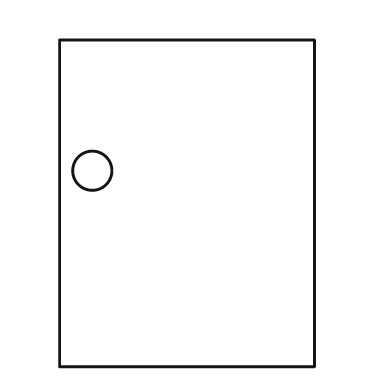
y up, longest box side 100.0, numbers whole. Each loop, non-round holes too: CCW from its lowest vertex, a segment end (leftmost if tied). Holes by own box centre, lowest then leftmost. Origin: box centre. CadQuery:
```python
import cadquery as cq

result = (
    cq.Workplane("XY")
    .moveTo(-39.0, -50.0)
    .lineTo(39.0, -50.0)
    .lineTo(39.0, 50.0)
    .lineTo(-39.0, 50.0)
    .close()
    .moveTo(-29.0, 10.0)
    .circle(6.0)
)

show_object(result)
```